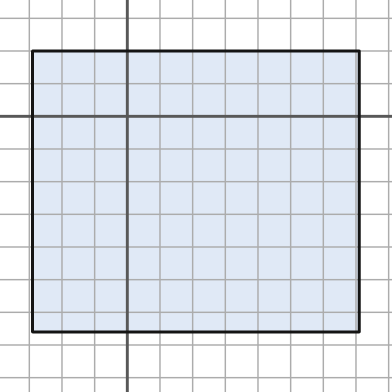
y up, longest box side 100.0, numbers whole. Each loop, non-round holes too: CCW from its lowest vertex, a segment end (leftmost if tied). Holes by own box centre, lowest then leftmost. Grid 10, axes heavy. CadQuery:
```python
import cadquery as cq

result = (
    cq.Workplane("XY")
    .moveTo(-29.0, -66.0)
    .lineTo(71.0, -66.0)
    .lineTo(71.0, 20.0)
    .lineTo(-29.0, 20.0)
    .close()
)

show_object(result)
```